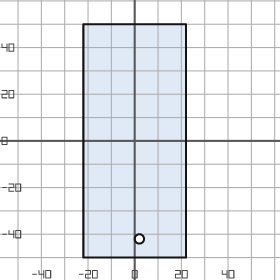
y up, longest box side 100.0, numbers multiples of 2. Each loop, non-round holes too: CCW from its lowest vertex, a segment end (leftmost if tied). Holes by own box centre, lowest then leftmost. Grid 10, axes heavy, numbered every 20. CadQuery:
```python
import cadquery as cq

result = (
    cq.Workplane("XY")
    .moveTo(-22.0, -50.0)
    .lineTo(22.0, -50.0)
    .lineTo(22.0, 50.0)
    .lineTo(-22.0, 50.0)
    .close()
    .moveTo(2.0, -42.0)
    .circle(2.0)
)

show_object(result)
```